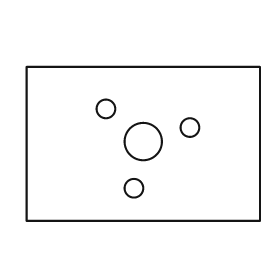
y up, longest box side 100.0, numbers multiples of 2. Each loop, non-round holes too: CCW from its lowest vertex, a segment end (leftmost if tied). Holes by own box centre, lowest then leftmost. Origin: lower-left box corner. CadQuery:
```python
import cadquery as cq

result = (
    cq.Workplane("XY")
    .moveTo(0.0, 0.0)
    .lineTo(100.0, 0.0)
    .lineTo(100.0, 66.0)
    .lineTo(0.0, 66.0)
    .close()
    .moveTo(46.0, 14.0)
    .circle(4.0)
    .moveTo(50.0, 34.0)
    .circle(8.0)
    .moveTo(70.0, 40.0)
    .circle(4.0)
    .moveTo(34.0, 48.0)
    .circle(4.0)
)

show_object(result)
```